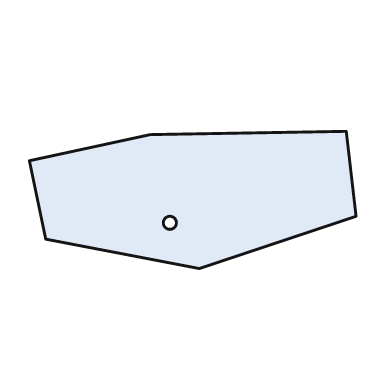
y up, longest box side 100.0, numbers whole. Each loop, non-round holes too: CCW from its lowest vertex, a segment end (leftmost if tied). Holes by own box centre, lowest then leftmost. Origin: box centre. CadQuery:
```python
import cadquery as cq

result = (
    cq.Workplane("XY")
    .moveTo(2.0, -21.0)
    .lineTo(50.0, -5.0)
    .lineTo(47.0, 21.0)
    .lineTo(-13.0, 20.0)
    .lineTo(-50.0, 12.0)
    .lineTo(-45.0, -12.0)
    .close()
    .moveTo(-7.0, -7.0)
    .circle(2.0)
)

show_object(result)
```